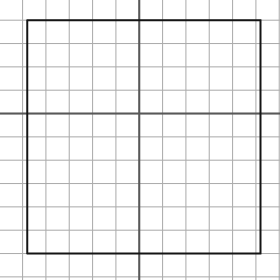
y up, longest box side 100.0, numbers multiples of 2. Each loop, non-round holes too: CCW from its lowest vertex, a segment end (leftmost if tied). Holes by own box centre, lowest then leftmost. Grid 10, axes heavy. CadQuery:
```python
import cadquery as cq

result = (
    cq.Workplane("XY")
    .moveTo(-48.0, -60.0)
    .lineTo(52.0, -60.0)
    .lineTo(52.0, 40.0)
    .lineTo(-48.0, 40.0)
    .close()
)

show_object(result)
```